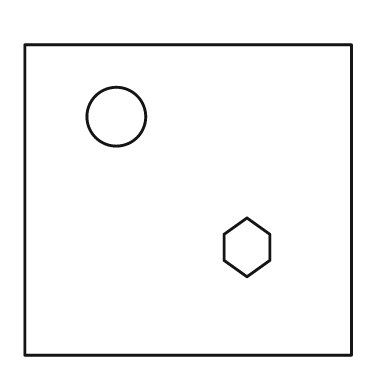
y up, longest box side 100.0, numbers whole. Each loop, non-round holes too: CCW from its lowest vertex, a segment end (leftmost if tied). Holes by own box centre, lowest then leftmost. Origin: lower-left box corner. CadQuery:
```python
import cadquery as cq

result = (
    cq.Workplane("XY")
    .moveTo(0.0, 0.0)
    .lineTo(100.0, 0.0)
    .lineTo(100.0, 95.0)
    .lineTo(0.0, 95.0)
    .close()
    .moveTo(68.0, 24.0)
    .lineTo(75.0, 29.0)
    .lineTo(75.0, 37.0)
    .lineTo(68.0, 42.0)
    .lineTo(61.0, 37.0)
    .lineTo(61.0, 29.0)
    .close()
    .moveTo(28.0, 73.0)
    .circle(9.0)
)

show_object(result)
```